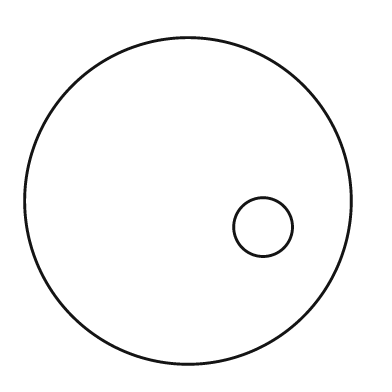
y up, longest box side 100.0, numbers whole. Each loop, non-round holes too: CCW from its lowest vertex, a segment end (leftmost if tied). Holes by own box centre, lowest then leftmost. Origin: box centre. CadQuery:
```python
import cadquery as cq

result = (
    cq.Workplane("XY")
    .moveTo(0.0, 0.0)
    .circle(50.0)
    .moveTo(23.0, -8.0)
    .circle(9.0)
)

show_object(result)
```